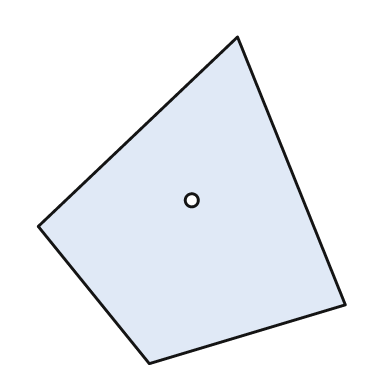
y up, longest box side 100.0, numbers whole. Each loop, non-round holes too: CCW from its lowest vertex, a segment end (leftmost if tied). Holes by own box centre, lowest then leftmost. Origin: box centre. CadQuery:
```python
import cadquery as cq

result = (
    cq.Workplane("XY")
    .moveTo(-13.0, -50.0)
    .lineTo(47.0, -32.0)
    .lineTo(14.0, 50.0)
    .lineTo(-47.0, -8.0)
    .close()
    .moveTo(0.0, 0.0)
    .circle(2.0)
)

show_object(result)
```